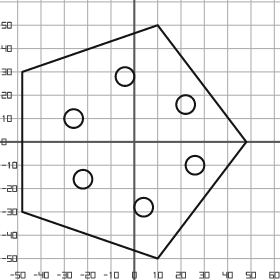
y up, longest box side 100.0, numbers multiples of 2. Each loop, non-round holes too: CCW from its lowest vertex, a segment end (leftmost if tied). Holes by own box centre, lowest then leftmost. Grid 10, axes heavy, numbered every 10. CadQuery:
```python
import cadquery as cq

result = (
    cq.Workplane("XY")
    .moveTo(10.0, -50.0)
    .lineTo(48.0, 0.0)
    .lineTo(10.0, 50.0)
    .lineTo(-48.0, 30.0)
    .lineTo(-48.0, -30.0)
    .close()
    .moveTo(4.0, -28.0)
    .circle(4.0)
    .moveTo(-22.0, -16.0)
    .circle(4.0)
    .moveTo(26.0, -10.0)
    .circle(4.0)
    .moveTo(-26.0, 10.0)
    .circle(4.0)
    .moveTo(22.0, 16.0)
    .circle(4.0)
    .moveTo(-4.0, 28.0)
    .circle(4.0)
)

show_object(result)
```